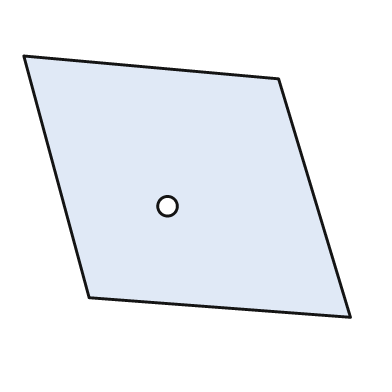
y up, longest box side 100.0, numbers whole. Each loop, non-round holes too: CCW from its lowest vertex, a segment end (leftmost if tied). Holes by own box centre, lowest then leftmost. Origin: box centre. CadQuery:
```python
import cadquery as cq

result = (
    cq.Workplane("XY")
    .moveTo(50.0, -40.0)
    .lineTo(28.0, 33.0)
    .lineTo(-50.0, 40.0)
    .lineTo(-30.0, -34.0)
    .close()
    .moveTo(-6.0, -6.0)
    .circle(3.0)
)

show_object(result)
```